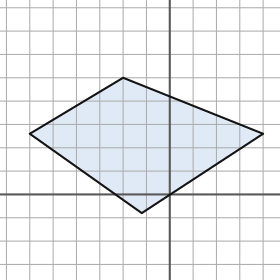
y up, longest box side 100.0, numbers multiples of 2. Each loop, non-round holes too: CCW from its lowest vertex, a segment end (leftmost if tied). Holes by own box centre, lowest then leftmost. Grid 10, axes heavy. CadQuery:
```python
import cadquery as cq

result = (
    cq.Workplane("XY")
    .moveTo(-12.0, -8.0)
    .lineTo(40.0, 26.0)
    .lineTo(-20.0, 50.0)
    .lineTo(-60.0, 26.0)
    .close()
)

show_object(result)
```